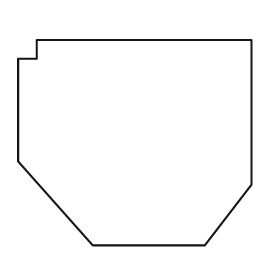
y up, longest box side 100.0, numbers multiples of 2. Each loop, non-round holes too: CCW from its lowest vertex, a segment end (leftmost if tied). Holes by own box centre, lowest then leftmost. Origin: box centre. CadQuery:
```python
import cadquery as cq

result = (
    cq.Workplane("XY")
    .moveTo(-18.0, -44.0)
    .lineTo(30.0, -44.0)
    .lineTo(50.0, -18.0)
    .lineTo(50.0, 44.0)
    .lineTo(-42.0, 44.0)
    .lineTo(-42.0, 36.0)
    .lineTo(-50.0, 36.0)
    .lineTo(-50.0, -8.0)
    .close()
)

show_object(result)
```